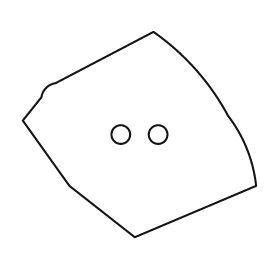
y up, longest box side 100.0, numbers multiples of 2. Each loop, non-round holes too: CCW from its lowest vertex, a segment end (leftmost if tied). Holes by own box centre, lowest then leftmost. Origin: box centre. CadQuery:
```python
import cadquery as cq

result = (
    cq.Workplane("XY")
    .moveTo(-2.0, -44.0)
    .lineTo(50.0, -22.0)
    .threePointArc((46.0, -6.0), (38.0, 8.0))
    .threePointArc((24.0, 28.0), (6.0, 44.0))
    .lineTo(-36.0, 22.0)
    .threePointArc((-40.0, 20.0), (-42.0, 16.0))
    .lineTo(-50.0, 6.0)
    .lineTo(-30.0, -22.0)
    .close()
    .moveTo(-8.0, 0.0)
    .circle(4.0)
    .moveTo(8.0, 0.0)
    .circle(4.0)
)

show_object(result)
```